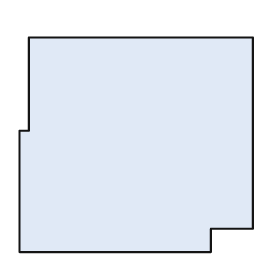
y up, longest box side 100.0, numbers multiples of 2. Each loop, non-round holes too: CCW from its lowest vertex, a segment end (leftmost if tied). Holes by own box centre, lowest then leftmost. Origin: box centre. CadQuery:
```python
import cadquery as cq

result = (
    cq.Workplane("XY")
    .moveTo(-50.0, -46.0)
    .lineTo(32.0, -46.0)
    .lineTo(32.0, -36.0)
    .lineTo(50.0, -36.0)
    .lineTo(50.0, 46.0)
    .lineTo(-46.0, 46.0)
    .lineTo(-46.0, 6.0)
    .lineTo(-50.0, 6.0)
    .close()
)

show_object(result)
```